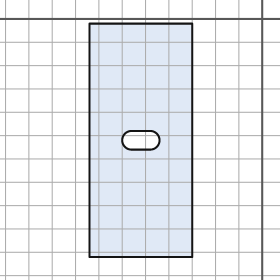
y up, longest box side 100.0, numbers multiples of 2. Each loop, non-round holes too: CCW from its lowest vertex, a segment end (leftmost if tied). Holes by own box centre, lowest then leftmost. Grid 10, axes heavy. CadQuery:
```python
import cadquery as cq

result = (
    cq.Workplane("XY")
    .moveTo(-74.0, -102.0)
    .lineTo(-30.0, -102.0)
    .lineTo(-30.0, -2.0)
    .lineTo(-74.0, -2.0)
    .close()
    .moveTo(-56.0, -56.0)
    .lineTo(-48.0, -56.0)
    .threePointArc((-44.0, -52.0), (-48.0, -48.0))
    .lineTo(-56.0, -48.0)
    .threePointArc((-60.0, -52.0), (-56.0, -56.0))
    .close()
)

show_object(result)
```